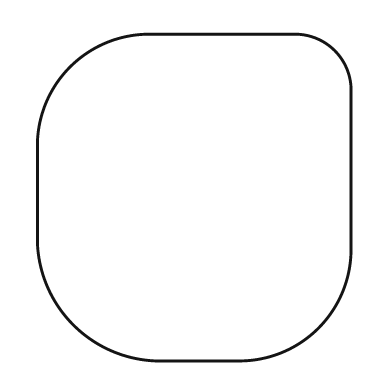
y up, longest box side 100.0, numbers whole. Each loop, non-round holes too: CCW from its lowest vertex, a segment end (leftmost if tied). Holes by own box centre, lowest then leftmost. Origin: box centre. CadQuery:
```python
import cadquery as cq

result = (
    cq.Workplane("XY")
    .moveTo(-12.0, -50.0)
    .lineTo(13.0, -50.0)
    .threePointArc((38.0, -40.0), (48.0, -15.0))
    .lineTo(48.0, 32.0)
    .threePointArc((43.0, 45.0), (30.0, 50.0))
    .lineTo(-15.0, 50.0)
    .threePointArc((-38.0, 40.0), (-48.0, 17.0))
    .lineTo(-48.0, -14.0)
    .threePointArc((-37.0, -39.0), (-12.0, -50.0))
    .close()
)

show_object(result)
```